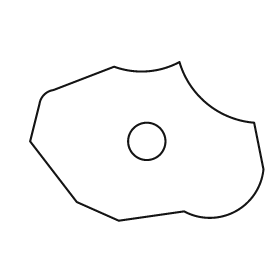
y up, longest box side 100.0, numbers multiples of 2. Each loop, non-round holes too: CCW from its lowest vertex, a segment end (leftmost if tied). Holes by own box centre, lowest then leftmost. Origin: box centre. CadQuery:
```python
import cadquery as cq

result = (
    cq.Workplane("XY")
    .moveTo(-12.0, -34.0)
    .lineTo(16.0, -30.0)
    .threePointArc((38.0, -30.0), (50.0, -12.0))
    .lineTo(46.0, 8.0)
    .threePointArc((26.0, 16.0), (14.0, 34.0))
    .threePointArc((0.0, 30.0), (-14.0, 32.0))
    .lineTo(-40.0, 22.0)
    .threePointArc((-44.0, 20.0), (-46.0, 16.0))
    .lineTo(-50.0, 0.0)
    .lineTo(-30.0, -26.0)
    .close()
    .moveTo(0.0, 0.0)
    .circle(8.0)
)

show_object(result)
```